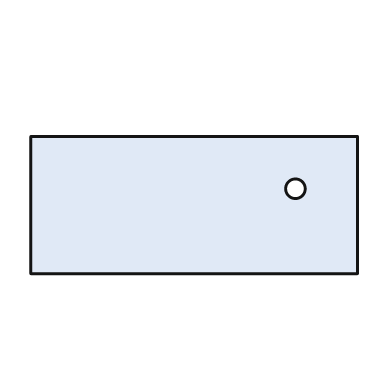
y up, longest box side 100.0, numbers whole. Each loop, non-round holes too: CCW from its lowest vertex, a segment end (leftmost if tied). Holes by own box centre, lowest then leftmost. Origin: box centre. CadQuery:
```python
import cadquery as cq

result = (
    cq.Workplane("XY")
    .moveTo(-50.0, -21.0)
    .lineTo(50.0, -21.0)
    .lineTo(50.0, 21.0)
    .lineTo(-50.0, 21.0)
    .close()
    .moveTo(31.0, 5.0)
    .circle(3.0)
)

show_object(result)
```